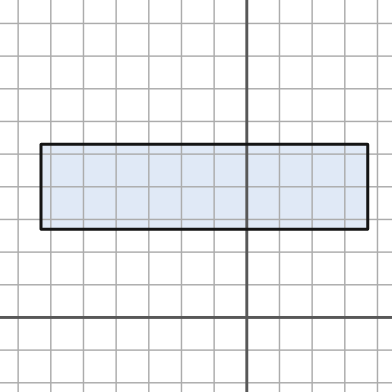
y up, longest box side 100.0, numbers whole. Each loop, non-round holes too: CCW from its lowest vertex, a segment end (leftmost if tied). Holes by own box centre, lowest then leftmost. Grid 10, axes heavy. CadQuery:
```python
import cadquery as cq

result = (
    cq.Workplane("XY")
    .moveTo(-63.0, 27.0)
    .lineTo(37.0, 27.0)
    .lineTo(37.0, 53.0)
    .lineTo(-63.0, 53.0)
    .close()
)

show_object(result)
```